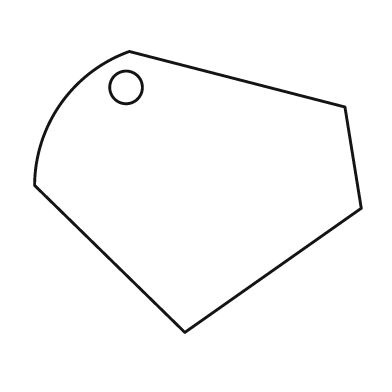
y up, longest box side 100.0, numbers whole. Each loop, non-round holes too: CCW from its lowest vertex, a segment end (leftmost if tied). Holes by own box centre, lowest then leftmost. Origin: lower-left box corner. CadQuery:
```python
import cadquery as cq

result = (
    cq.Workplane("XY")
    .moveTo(46.0, 0.0)
    .lineTo(100.0, 38.0)
    .lineTo(95.0, 69.0)
    .lineTo(29.0, 86.0)
    .threePointArc((8.0, 70.0), (0.0, 45.0))
    .close()
    .moveTo(28.0, 75.0)
    .circle(5.0)
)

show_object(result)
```